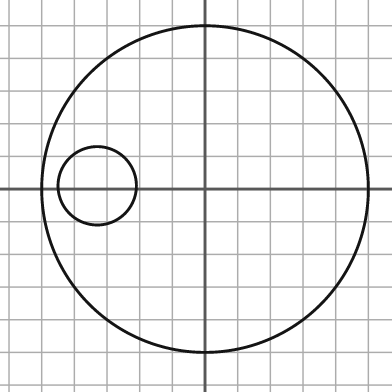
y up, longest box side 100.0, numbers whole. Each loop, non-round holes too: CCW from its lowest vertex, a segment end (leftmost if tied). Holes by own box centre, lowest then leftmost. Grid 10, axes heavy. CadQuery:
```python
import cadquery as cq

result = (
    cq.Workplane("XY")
    .moveTo(0.0, 0.0)
    .circle(50.0)
    .moveTo(-33.0, 1.0)
    .circle(12.0)
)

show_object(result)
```